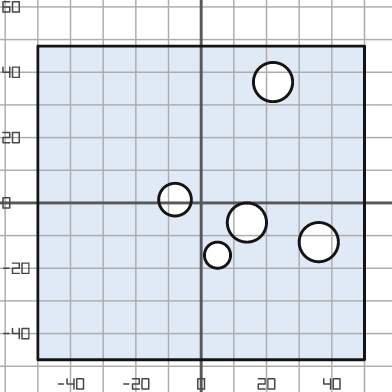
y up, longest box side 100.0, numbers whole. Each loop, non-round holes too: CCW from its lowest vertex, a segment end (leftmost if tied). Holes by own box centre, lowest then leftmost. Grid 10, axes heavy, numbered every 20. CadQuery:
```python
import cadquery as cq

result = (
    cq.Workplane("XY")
    .moveTo(-50.0, -48.0)
    .lineTo(50.0, -48.0)
    .lineTo(50.0, 48.0)
    .lineTo(-50.0, 48.0)
    .close()
    .moveTo(5.0, -16.0)
    .circle(4.0)
    .moveTo(36.0, -12.0)
    .circle(6.0)
    .moveTo(14.0, -6.0)
    .circle(6.0)
    .moveTo(-8.0, 1.0)
    .circle(5.0)
    .moveTo(22.0, 37.0)
    .circle(6.0)
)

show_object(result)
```